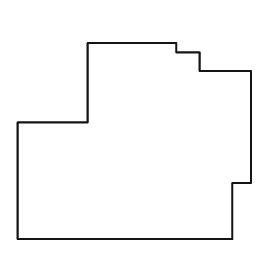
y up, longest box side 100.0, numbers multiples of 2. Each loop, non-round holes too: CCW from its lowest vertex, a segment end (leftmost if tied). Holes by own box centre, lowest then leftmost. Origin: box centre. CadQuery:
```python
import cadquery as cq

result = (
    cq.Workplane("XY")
    .moveTo(-50.0, -42.0)
    .lineTo(42.0, -42.0)
    .lineTo(42.0, -18.0)
    .lineTo(50.0, -18.0)
    .lineTo(50.0, 30.0)
    .lineTo(28.0, 30.0)
    .lineTo(28.0, 38.0)
    .lineTo(18.0, 38.0)
    .lineTo(18.0, 42.0)
    .lineTo(-20.0, 42.0)
    .lineTo(-20.0, 8.0)
    .lineTo(-50.0, 8.0)
    .close()
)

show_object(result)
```